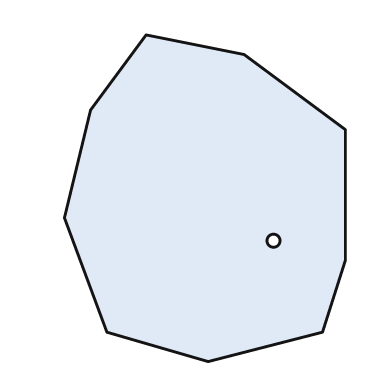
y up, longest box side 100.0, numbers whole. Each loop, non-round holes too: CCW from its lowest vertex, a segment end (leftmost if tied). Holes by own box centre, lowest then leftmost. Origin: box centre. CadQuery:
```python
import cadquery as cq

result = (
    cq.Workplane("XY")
    .moveTo(1.0, -50.0)
    .lineTo(36.0, -41.0)
    .lineTo(43.0, -19.0)
    .lineTo(43.0, 21.0)
    .lineTo(12.0, 44.0)
    .lineTo(-18.0, 50.0)
    .lineTo(-35.0, 27.0)
    .lineTo(-43.0, -6.0)
    .lineTo(-30.0, -41.0)
    .close()
    .moveTo(21.0, -13.0)
    .circle(2.0)
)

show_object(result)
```